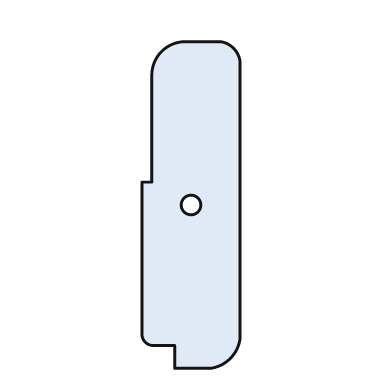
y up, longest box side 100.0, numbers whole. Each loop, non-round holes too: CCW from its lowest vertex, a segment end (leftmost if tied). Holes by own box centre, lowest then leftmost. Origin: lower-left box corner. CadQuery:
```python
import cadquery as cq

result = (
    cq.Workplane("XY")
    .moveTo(10.0, 0.0)
    .lineTo(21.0, 0.0)
    .threePointArc((27.0, 3.0), (30.0, 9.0))
    .lineTo(30.0, 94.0)
    .threePointArc((28.0, 98.0), (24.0, 100.0))
    .lineTo(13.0, 100.0)
    .threePointArc((6.0, 97.0), (3.0, 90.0))
    .lineTo(3.0, 57.0)
    .lineTo(0.0, 57.0)
    .lineTo(0.0, 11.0)
    .threePointArc((1.0, 8.0), (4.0, 7.0))
    .lineTo(10.0, 7.0)
    .close()
    .moveTo(15.0, 50.0)
    .circle(3.0)
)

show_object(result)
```